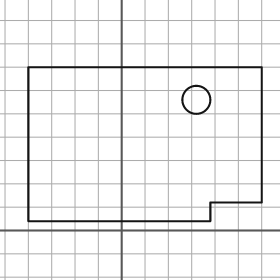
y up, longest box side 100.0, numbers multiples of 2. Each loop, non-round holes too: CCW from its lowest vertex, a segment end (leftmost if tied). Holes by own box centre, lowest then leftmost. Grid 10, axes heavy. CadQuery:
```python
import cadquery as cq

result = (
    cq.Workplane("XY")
    .moveTo(-40.0, 4.0)
    .lineTo(38.0, 4.0)
    .lineTo(38.0, 12.0)
    .lineTo(60.0, 12.0)
    .lineTo(60.0, 70.0)
    .lineTo(-40.0, 70.0)
    .close()
    .moveTo(32.0, 56.0)
    .circle(6.0)
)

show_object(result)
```